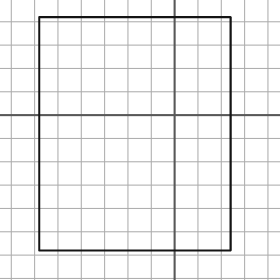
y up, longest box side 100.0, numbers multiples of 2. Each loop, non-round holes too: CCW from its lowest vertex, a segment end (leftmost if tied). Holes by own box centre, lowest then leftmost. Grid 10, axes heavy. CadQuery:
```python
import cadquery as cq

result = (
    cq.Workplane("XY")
    .moveTo(-58.0, -58.0)
    .lineTo(24.0, -58.0)
    .lineTo(24.0, 42.0)
    .lineTo(-58.0, 42.0)
    .close()
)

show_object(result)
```